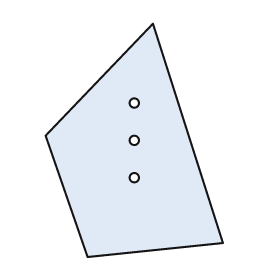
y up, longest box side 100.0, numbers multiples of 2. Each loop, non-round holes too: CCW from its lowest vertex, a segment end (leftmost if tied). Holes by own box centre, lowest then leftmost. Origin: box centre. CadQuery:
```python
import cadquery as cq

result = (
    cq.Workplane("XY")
    .moveTo(-20.0, -50.0)
    .lineTo(38.0, -44.0)
    .lineTo(8.0, 50.0)
    .lineTo(-38.0, 2.0)
    .close()
    .moveTo(0.0, -16.0)
    .circle(2.0)
    .moveTo(0.0, 0.0)
    .circle(2.0)
    .moveTo(0.0, 16.0)
    .circle(2.0)
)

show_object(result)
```